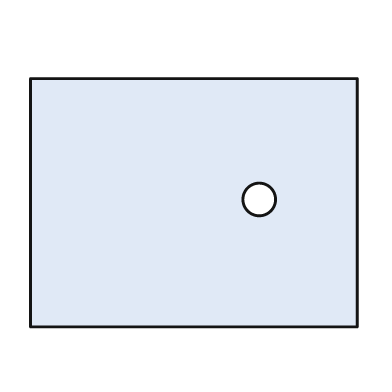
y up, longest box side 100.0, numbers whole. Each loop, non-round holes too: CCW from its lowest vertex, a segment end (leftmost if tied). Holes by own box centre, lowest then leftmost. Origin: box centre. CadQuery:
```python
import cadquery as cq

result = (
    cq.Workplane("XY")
    .moveTo(-50.0, -38.0)
    .lineTo(50.0, -38.0)
    .lineTo(50.0, 38.0)
    .lineTo(-50.0, 38.0)
    .close()
    .moveTo(20.0, 1.0)
    .circle(5.0)
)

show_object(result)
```